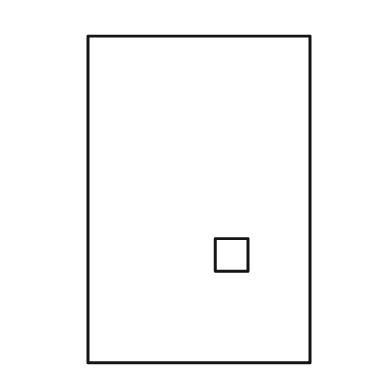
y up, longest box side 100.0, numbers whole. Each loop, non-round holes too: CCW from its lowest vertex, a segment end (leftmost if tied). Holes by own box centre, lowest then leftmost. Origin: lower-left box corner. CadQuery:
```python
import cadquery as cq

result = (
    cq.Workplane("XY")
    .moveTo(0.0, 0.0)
    .lineTo(68.0, 0.0)
    .lineTo(68.0, 100.0)
    .lineTo(0.0, 100.0)
    .close()
    .moveTo(39.0, 28.0)
    .lineTo(49.0, 28.0)
    .lineTo(49.0, 38.0)
    .lineTo(39.0, 38.0)
    .close()
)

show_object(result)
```